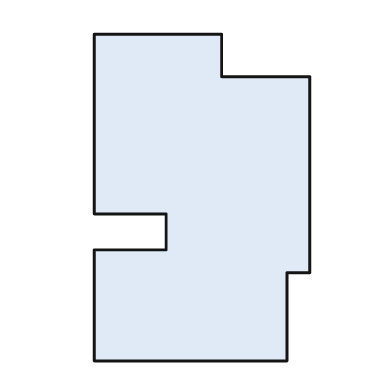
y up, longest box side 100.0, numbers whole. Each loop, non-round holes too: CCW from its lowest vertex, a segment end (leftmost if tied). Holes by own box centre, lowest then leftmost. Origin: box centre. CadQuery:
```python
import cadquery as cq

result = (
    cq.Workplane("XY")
    .moveTo(-33.0, -50.0)
    .lineTo(26.0, -50.0)
    .lineTo(26.0, -23.0)
    .lineTo(33.0, -23.0)
    .lineTo(33.0, 37.0)
    .lineTo(6.0, 37.0)
    .lineTo(6.0, 50.0)
    .lineTo(-33.0, 50.0)
    .lineTo(-33.0, -5.0)
    .lineTo(-11.0, -5.0)
    .lineTo(-11.0, -16.0)
    .lineTo(-33.0, -16.0)
    .close()
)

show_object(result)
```